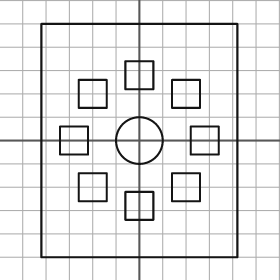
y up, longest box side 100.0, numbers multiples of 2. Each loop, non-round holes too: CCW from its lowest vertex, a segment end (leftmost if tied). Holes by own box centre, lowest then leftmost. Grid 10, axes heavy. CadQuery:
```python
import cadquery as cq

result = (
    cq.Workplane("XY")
    .moveTo(-42.0, -50.0)
    .lineTo(42.0, -50.0)
    .lineTo(42.0, 50.0)
    .lineTo(-42.0, 50.0)
    .close()
    .moveTo(-6.0, -34.0)
    .lineTo(6.0, -34.0)
    .lineTo(6.0, -22.0)
    .lineTo(-6.0, -22.0)
    .close()
    .moveTo(-26.0, -26.0)
    .lineTo(-14.0, -26.0)
    .lineTo(-14.0, -14.0)
    .lineTo(-26.0, -14.0)
    .close()
    .moveTo(14.0, -26.0)
    .lineTo(26.0, -26.0)
    .lineTo(26.0, -14.0)
    .lineTo(14.0, -14.0)
    .close()
    .moveTo(-34.0, -6.0)
    .lineTo(-22.0, -6.0)
    .lineTo(-22.0, 6.0)
    .lineTo(-34.0, 6.0)
    .close()
    .moveTo(0.0, 0.0)
    .circle(10.0)
    .moveTo(22.0, -6.0)
    .lineTo(34.0, -6.0)
    .lineTo(34.0, 6.0)
    .lineTo(22.0, 6.0)
    .close()
    .moveTo(-26.0, 14.0)
    .lineTo(-14.0, 14.0)
    .lineTo(-14.0, 26.0)
    .lineTo(-26.0, 26.0)
    .close()
    .moveTo(14.0, 14.0)
    .lineTo(26.0, 14.0)
    .lineTo(26.0, 26.0)
    .lineTo(14.0, 26.0)
    .close()
    .moveTo(-6.0, 22.0)
    .lineTo(6.0, 22.0)
    .lineTo(6.0, 34.0)
    .lineTo(-6.0, 34.0)
    .close()
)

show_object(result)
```